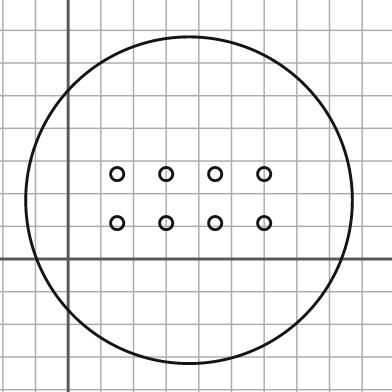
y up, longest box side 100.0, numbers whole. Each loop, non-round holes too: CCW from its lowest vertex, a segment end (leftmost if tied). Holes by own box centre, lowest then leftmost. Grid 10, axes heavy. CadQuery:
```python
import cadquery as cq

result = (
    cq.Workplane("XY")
    .moveTo(37.0, 18.0)
    .circle(50.0)
    .moveTo(15.0, 11.0)
    .circle(2.0)
    .moveTo(30.0, 11.0)
    .circle(2.0)
    .moveTo(45.0, 11.0)
    .circle(2.0)
    .moveTo(60.0, 11.0)
    .circle(2.0)
    .moveTo(15.0, 26.0)
    .circle(2.0)
    .moveTo(30.0, 26.0)
    .circle(2.0)
    .moveTo(45.0, 26.0)
    .circle(2.0)
    .moveTo(60.0, 26.0)
    .circle(2.0)
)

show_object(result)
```